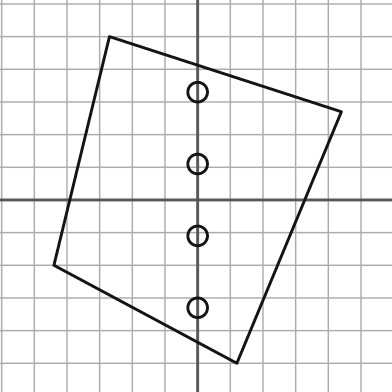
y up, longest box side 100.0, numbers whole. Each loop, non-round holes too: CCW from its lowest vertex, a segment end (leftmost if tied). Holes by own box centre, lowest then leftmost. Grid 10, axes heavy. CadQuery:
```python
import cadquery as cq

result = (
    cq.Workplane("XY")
    .moveTo(12.0, -50.0)
    .lineTo(44.0, 27.0)
    .lineTo(-27.0, 50.0)
    .lineTo(-44.0, -20.0)
    .close()
    .moveTo(0.0, -33.0)
    .circle(3.0)
    .moveTo(0.0, -11.0)
    .circle(3.0)
    .moveTo(0.0, 11.0)
    .circle(3.0)
    .moveTo(0.0, 33.0)
    .circle(3.0)
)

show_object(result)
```